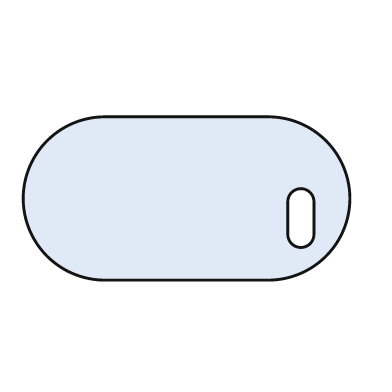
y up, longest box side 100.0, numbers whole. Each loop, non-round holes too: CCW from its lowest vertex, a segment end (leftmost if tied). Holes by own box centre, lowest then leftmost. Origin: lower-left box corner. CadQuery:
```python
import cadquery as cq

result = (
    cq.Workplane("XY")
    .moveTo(25.0, 0.0)
    .lineTo(75.0, 0.0)
    .threePointArc((100.0, 25.0), (75.0, 50.0))
    .lineTo(25.0, 50.0)
    .threePointArc((0.0, 25.0), (25.0, 0.0))
    .close()
    .moveTo(81.0, 14.0)
    .threePointArc((85.0, 10.0), (89.0, 14.0))
    .lineTo(89.0, 24.0)
    .threePointArc((85.0, 28.0), (81.0, 24.0))
    .close()
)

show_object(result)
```